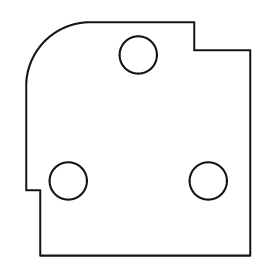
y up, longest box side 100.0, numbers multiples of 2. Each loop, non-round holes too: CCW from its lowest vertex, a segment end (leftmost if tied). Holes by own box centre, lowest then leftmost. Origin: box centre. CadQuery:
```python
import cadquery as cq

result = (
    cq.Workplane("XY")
    .moveTo(-42.0, -50.0)
    .lineTo(48.0, -50.0)
    .lineTo(48.0, 38.0)
    .lineTo(24.0, 38.0)
    .lineTo(24.0, 50.0)
    .lineTo(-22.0, 50.0)
    .threePointArc((-40.0, 42.0), (-48.0, 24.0))
    .lineTo(-48.0, -22.0)
    .lineTo(-42.0, -22.0)
    .close()
    .moveTo(-30.0, -18.0)
    .circle(8.0)
    .moveTo(30.0, -18.0)
    .circle(8.0)
    .moveTo(0.0, 36.0)
    .circle(8.0)
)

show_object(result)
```